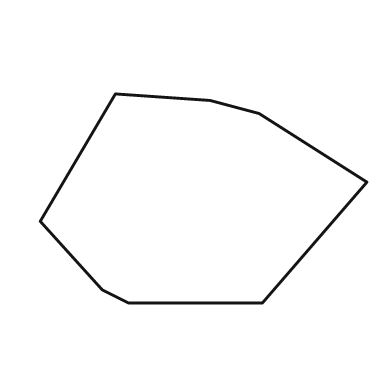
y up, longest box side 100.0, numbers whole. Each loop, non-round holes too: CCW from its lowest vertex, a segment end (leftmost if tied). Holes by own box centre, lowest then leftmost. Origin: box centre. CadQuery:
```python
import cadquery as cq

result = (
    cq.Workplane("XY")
    .moveTo(-23.0, -32.0)
    .lineTo(18.0, -32.0)
    .lineTo(50.0, 5.0)
    .lineTo(17.0, 26.0)
    .lineTo(2.0, 30.0)
    .lineTo(-27.0, 32.0)
    .lineTo(-50.0, -7.0)
    .lineTo(-31.0, -28.0)
    .close()
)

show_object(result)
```